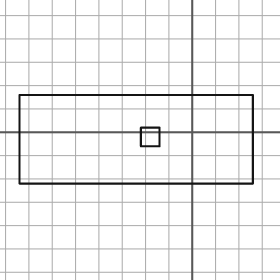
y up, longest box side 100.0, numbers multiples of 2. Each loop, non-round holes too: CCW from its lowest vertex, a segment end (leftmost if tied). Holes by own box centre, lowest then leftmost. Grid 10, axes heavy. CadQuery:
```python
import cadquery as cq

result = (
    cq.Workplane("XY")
    .moveTo(-74.0, -22.0)
    .lineTo(26.0, -22.0)
    .lineTo(26.0, 16.0)
    .lineTo(-74.0, 16.0)
    .close()
    .moveTo(-22.0, -6.0)
    .lineTo(-14.0, -6.0)
    .lineTo(-14.0, 2.0)
    .lineTo(-22.0, 2.0)
    .close()
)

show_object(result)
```